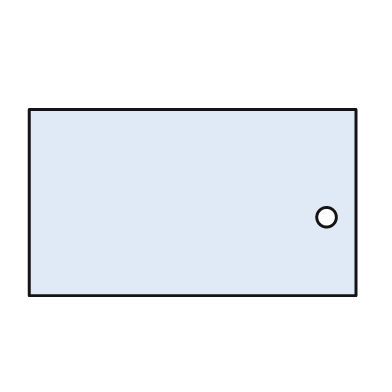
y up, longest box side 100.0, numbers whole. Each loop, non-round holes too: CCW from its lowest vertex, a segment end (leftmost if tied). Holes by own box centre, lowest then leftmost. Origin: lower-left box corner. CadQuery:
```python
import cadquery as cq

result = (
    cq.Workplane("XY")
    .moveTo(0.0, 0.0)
    .lineTo(100.0, 0.0)
    .lineTo(100.0, 57.0)
    .lineTo(0.0, 57.0)
    .close()
    .moveTo(91.0, 24.0)
    .circle(3.0)
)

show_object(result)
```